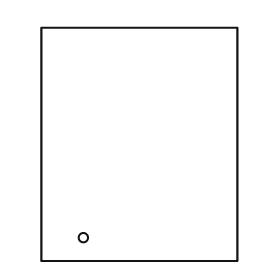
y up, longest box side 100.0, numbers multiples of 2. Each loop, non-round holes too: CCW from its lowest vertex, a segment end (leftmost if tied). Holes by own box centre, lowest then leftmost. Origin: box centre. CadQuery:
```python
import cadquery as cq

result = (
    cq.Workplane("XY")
    .moveTo(-42.0, -50.0)
    .lineTo(42.0, -50.0)
    .lineTo(42.0, 50.0)
    .lineTo(-42.0, 50.0)
    .close()
    .moveTo(-24.0, -40.0)
    .circle(2.0)
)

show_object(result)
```